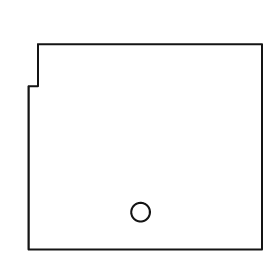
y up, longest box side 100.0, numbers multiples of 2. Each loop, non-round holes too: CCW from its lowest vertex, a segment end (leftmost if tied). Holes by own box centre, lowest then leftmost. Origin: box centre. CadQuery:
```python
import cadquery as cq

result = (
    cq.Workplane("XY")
    .moveTo(-50.0, -44.0)
    .lineTo(50.0, -44.0)
    .lineTo(50.0, 44.0)
    .lineTo(-46.0, 44.0)
    .lineTo(-46.0, 26.0)
    .lineTo(-50.0, 26.0)
    .close()
    .moveTo(-2.0, -28.0)
    .circle(4.0)
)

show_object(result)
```